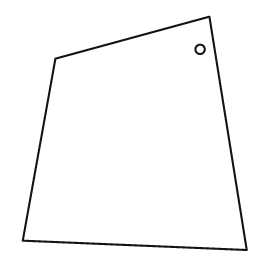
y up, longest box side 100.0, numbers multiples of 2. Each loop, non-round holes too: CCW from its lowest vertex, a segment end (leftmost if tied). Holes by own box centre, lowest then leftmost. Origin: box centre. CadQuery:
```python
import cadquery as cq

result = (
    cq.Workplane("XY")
    .moveTo(48.0, -50.0)
    .lineTo(32.0, 50.0)
    .lineTo(-34.0, 32.0)
    .lineTo(-48.0, -46.0)
    .close()
    .moveTo(28.0, 36.0)
    .circle(2.0)
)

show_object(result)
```